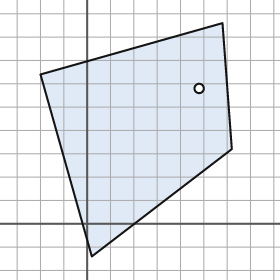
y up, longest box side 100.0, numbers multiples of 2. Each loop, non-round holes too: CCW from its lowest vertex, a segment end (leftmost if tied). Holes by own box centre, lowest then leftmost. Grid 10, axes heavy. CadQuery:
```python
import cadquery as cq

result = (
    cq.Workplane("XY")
    .moveTo(2.0, -14.0)
    .lineTo(62.0, 32.0)
    .lineTo(58.0, 86.0)
    .lineTo(-20.0, 64.0)
    .close()
    .moveTo(48.0, 58.0)
    .circle(2.0)
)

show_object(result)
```